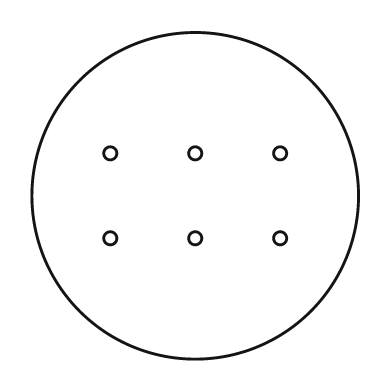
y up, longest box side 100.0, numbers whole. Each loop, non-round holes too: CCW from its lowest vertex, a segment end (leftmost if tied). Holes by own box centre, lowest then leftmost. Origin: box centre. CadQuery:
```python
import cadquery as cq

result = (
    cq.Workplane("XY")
    .moveTo(0.0, 0.0)
    .circle(50.0)
    .moveTo(-26.0, -13.0)
    .circle(2.0)
    .moveTo(0.0, -13.0)
    .circle(2.0)
    .moveTo(26.0, -13.0)
    .circle(2.0)
    .moveTo(-26.0, 13.0)
    .circle(2.0)
    .moveTo(0.0, 13.0)
    .circle(2.0)
    .moveTo(26.0, 13.0)
    .circle(2.0)
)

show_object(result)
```